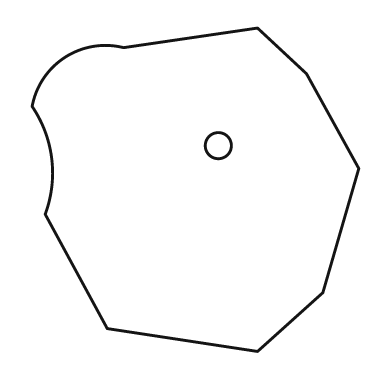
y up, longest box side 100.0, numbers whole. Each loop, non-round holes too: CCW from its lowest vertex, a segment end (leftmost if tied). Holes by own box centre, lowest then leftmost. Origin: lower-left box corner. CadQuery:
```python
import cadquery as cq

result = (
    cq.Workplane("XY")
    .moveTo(69.0, 0.0)
    .lineTo(89.0, 18.0)
    .lineTo(100.0, 56.0)
    .lineTo(84.0, 85.0)
    .lineTo(69.0, 99.0)
    .lineTo(28.0, 93.0)
    .threePointArc((10.0, 90.0), (0.0, 75.0))
    .threePointArc((6.0, 59.0), (4.0, 42.0))
    .lineTo(23.0, 7.0)
    .close()
    .moveTo(57.0, 63.0)
    .circle(4.0)
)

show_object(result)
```